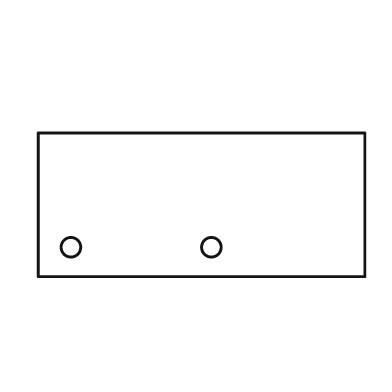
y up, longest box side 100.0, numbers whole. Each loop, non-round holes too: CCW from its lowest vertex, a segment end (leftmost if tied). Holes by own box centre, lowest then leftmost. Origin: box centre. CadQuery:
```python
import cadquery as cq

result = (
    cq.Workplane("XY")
    .moveTo(-50.0, -22.0)
    .lineTo(50.0, -22.0)
    .lineTo(50.0, 22.0)
    .lineTo(-50.0, 22.0)
    .close()
    .moveTo(-40.0, -13.0)
    .circle(3.0)
    .moveTo(3.0, -13.0)
    .circle(3.0)
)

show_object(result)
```